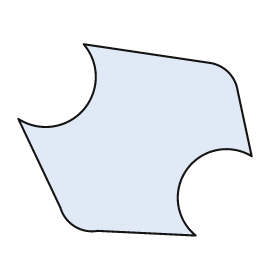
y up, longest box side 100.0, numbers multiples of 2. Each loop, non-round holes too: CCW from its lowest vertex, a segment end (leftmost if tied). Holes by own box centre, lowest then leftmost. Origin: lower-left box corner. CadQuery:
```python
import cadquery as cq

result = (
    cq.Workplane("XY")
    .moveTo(76.0, 0.0)
    .threePointArc((72.0, 28.0), (100.0, 34.0))
    .lineTo(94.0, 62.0)
    .threePointArc((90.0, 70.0), (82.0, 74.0))
    .lineTo(28.0, 82.0)
    .threePointArc((28.0, 54.0), (0.0, 50.0))
    .lineTo(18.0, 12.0)
    .threePointArc((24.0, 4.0), (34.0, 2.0))
    .close()
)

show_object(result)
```